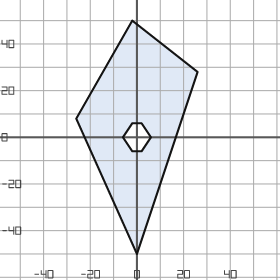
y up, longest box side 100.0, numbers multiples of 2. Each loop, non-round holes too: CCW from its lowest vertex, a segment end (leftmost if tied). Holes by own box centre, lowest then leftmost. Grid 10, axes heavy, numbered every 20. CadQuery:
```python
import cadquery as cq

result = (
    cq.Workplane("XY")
    .moveTo(0.0, -50.0)
    .lineTo(26.0, 28.0)
    .lineTo(-2.0, 50.0)
    .lineTo(-26.0, 8.0)
    .close()
    .moveTo(-2.0, -6.0)
    .lineTo(2.0, -6.0)
    .lineTo(6.0, 0.0)
    .lineTo(2.0, 6.0)
    .lineTo(-2.0, 6.0)
    .lineTo(-6.0, 0.0)
    .close()
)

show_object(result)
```